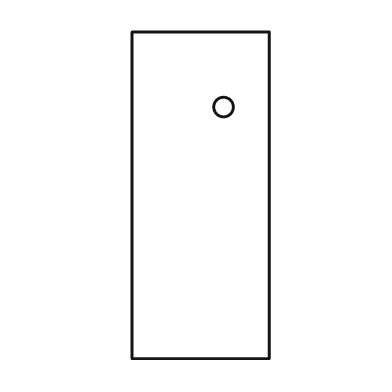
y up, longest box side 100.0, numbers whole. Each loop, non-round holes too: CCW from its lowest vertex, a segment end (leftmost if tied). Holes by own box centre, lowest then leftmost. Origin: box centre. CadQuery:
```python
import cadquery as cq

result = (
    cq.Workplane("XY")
    .moveTo(-21.0, -50.0)
    .lineTo(21.0, -50.0)
    .lineTo(21.0, 50.0)
    .lineTo(-21.0, 50.0)
    .close()
    .moveTo(7.0, 27.0)
    .circle(3.0)
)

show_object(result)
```